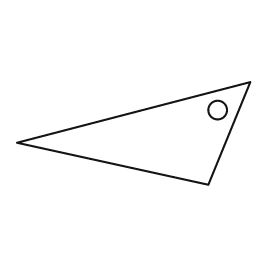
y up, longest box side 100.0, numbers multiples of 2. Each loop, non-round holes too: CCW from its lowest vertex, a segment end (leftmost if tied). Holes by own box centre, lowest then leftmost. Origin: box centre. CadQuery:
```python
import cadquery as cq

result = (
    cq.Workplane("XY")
    .moveTo(32.0, -22.0)
    .lineTo(50.0, 22.0)
    .lineTo(-50.0, -4.0)
    .close()
    .moveTo(36.0, 10.0)
    .circle(4.0)
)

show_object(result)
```